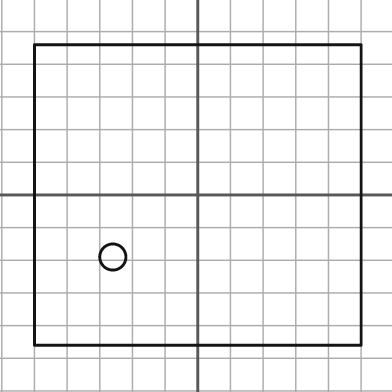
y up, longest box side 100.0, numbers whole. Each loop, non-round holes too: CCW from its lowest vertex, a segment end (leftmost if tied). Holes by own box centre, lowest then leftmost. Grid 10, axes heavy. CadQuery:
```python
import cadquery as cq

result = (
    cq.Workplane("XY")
    .moveTo(-50.0, -46.0)
    .lineTo(50.0, -46.0)
    .lineTo(50.0, 46.0)
    .lineTo(-50.0, 46.0)
    .close()
    .moveTo(-26.0, -19.0)
    .circle(4.0)
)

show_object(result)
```